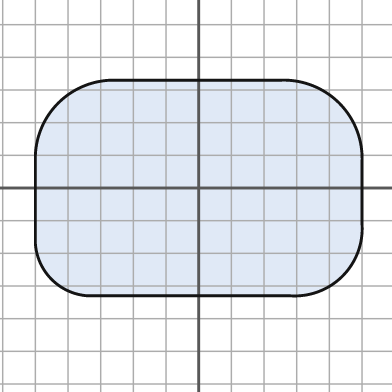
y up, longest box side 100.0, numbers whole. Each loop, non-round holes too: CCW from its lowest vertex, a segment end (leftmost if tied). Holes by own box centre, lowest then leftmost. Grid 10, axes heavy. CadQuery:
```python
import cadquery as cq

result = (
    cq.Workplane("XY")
    .moveTo(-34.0, -33.0)
    .lineTo(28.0, -33.0)
    .threePointArc((44.0, -27.0), (50.0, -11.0))
    .lineTo(50.0, 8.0)
    .threePointArc((43.0, 26.0), (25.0, 33.0))
    .lineTo(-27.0, 33.0)
    .threePointArc((-43.0, 26.0), (-50.0, 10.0))
    .lineTo(-50.0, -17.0)
    .threePointArc((-45.0, -28.0), (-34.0, -33.0))
    .close()
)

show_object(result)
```